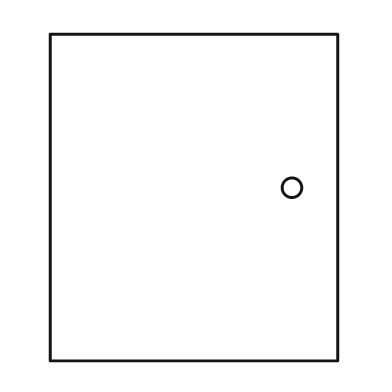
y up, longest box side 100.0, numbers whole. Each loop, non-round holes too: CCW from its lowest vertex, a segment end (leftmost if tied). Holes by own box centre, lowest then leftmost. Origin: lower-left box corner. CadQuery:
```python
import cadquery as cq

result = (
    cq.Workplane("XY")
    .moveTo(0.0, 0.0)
    .lineTo(88.0, 0.0)
    .lineTo(88.0, 100.0)
    .lineTo(0.0, 100.0)
    .close()
    .moveTo(74.0, 53.0)
    .circle(3.0)
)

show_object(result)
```